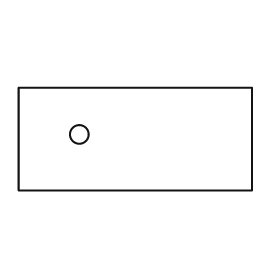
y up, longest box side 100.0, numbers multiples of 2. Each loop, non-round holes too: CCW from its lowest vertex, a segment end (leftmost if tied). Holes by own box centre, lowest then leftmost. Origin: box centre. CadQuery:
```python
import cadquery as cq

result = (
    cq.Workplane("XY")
    .moveTo(-50.0, -22.0)
    .lineTo(50.0, -22.0)
    .lineTo(50.0, 22.0)
    .lineTo(-50.0, 22.0)
    .close()
    .moveTo(-24.0, 2.0)
    .circle(4.0)
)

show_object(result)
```